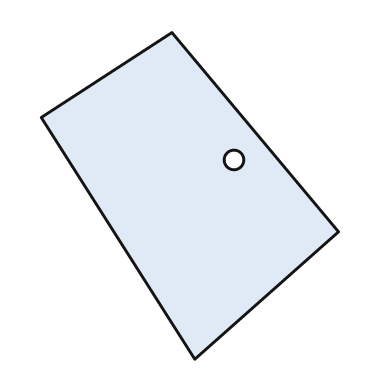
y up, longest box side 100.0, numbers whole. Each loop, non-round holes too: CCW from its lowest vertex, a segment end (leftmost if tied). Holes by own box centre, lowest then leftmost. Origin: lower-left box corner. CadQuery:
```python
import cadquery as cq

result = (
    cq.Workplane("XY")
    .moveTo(47.0, 0.0)
    .lineTo(91.0, 39.0)
    .lineTo(40.0, 100.0)
    .lineTo(0.0, 74.0)
    .close()
    .moveTo(59.0, 61.0)
    .circle(3.0)
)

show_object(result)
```